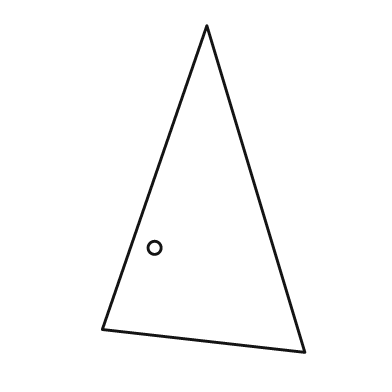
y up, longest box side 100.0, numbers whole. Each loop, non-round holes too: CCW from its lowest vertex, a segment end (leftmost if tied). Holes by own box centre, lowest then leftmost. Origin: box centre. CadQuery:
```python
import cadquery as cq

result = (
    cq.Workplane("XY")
    .moveTo(31.0, -50.0)
    .lineTo(1.0, 50.0)
    .lineTo(-31.0, -43.0)
    .close()
    .moveTo(-15.0, -18.0)
    .circle(2.0)
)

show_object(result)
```